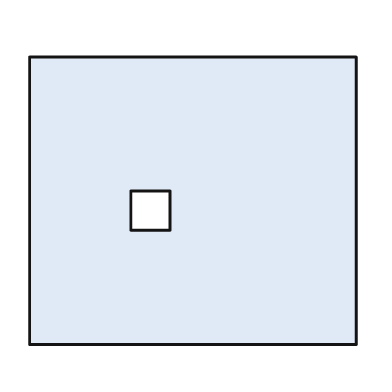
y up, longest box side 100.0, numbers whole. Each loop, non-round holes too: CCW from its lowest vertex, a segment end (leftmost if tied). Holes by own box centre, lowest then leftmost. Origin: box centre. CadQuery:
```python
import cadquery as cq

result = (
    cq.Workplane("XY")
    .moveTo(-50.0, -44.0)
    .lineTo(50.0, -44.0)
    .lineTo(50.0, 44.0)
    .lineTo(-50.0, 44.0)
    .close()
    .moveTo(-19.0, -9.0)
    .lineTo(-7.0, -9.0)
    .lineTo(-7.0, 3.0)
    .lineTo(-19.0, 3.0)
    .close()
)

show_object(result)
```